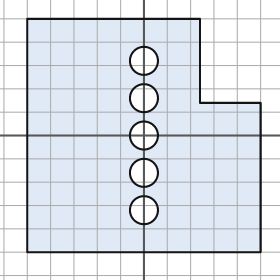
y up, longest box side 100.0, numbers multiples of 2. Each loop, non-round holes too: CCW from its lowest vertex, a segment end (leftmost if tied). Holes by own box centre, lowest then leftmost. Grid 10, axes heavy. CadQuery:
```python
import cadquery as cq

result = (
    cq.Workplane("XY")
    .moveTo(-50.0, -50.0)
    .lineTo(50.0, -50.0)
    .lineTo(50.0, 14.0)
    .lineTo(24.0, 14.0)
    .lineTo(24.0, 50.0)
    .lineTo(-50.0, 50.0)
    .close()
    .moveTo(0.0, -32.0)
    .circle(6.0)
    .moveTo(0.0, -16.0)
    .circle(6.0)
    .moveTo(0.0, 0.0)
    .circle(6.0)
    .moveTo(0.0, 16.0)
    .circle(6.0)
    .moveTo(0.0, 32.0)
    .circle(6.0)
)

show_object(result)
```